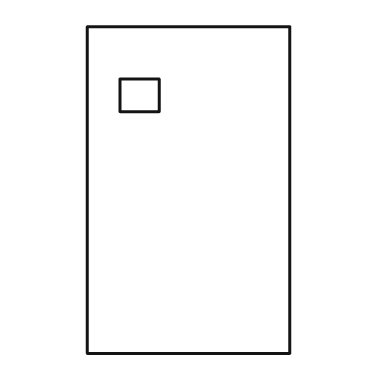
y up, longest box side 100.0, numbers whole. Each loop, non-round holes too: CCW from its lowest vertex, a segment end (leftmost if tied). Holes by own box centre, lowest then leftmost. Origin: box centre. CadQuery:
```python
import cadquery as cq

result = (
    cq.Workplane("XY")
    .moveTo(-31.0, -50.0)
    .lineTo(31.0, -50.0)
    .lineTo(31.0, 50.0)
    .lineTo(-31.0, 50.0)
    .close()
    .moveTo(-21.0, 24.0)
    .lineTo(-9.0, 24.0)
    .lineTo(-9.0, 34.0)
    .lineTo(-21.0, 34.0)
    .close()
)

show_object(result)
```